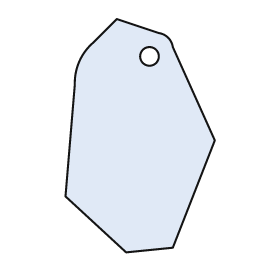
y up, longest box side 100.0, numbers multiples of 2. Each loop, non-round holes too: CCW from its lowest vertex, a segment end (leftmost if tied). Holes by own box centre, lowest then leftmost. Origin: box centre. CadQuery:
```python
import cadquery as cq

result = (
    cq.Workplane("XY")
    .moveTo(-6.0, -50.0)
    .lineTo(14.0, -48.0)
    .lineTo(32.0, -2.0)
    .lineTo(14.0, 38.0)
    .threePointArc((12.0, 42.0), (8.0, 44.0))
    .lineTo(-10.0, 50.0)
    .lineTo(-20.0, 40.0)
    .threePointArc((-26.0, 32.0), (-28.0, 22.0))
    .lineTo(-32.0, -26.0)
    .close()
    .moveTo(4.0, 34.0)
    .circle(4.0)
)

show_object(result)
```